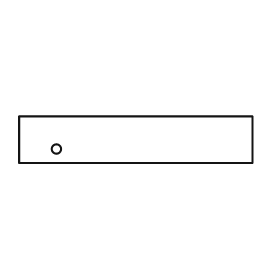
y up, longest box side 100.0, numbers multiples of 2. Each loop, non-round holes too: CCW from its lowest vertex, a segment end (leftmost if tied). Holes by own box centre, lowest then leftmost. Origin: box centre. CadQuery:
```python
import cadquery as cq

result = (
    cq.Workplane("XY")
    .moveTo(-50.0, -10.0)
    .lineTo(50.0, -10.0)
    .lineTo(50.0, 10.0)
    .lineTo(-50.0, 10.0)
    .close()
    .moveTo(-34.0, -4.0)
    .circle(2.0)
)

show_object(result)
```